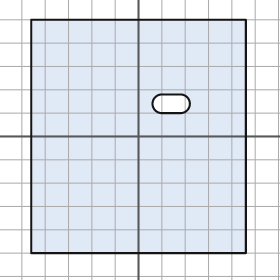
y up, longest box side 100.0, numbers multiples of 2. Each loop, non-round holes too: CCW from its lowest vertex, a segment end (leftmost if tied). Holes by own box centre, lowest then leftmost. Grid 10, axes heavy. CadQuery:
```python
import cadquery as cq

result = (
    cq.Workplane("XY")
    .moveTo(-46.0, -50.0)
    .lineTo(46.0, -50.0)
    .lineTo(46.0, 50.0)
    .lineTo(-46.0, 50.0)
    .close()
    .moveTo(10.0, 10.0)
    .lineTo(18.0, 10.0)
    .threePointArc((22.0, 14.0), (18.0, 18.0))
    .lineTo(10.0, 18.0)
    .threePointArc((6.0, 14.0), (10.0, 10.0))
    .close()
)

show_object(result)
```